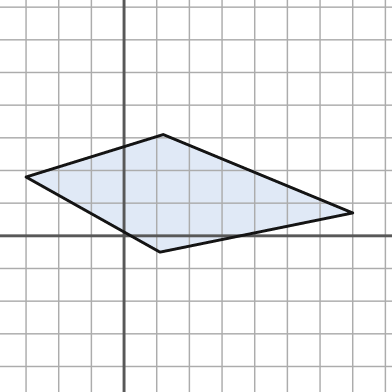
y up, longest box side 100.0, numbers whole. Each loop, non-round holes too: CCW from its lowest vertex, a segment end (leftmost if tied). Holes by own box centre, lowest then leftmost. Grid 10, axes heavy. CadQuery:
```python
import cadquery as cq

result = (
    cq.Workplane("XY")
    .moveTo(11.0, -5.0)
    .lineTo(70.0, 7.0)
    .lineTo(12.0, 31.0)
    .lineTo(-30.0, 18.0)
    .close()
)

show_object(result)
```